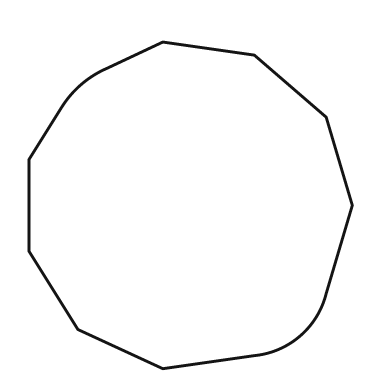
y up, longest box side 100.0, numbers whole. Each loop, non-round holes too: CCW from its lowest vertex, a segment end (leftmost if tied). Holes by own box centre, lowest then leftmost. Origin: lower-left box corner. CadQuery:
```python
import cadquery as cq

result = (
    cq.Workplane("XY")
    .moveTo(41.0, 0.0)
    .lineTo(69.0, 4.0)
    .threePointArc((83.0, 10.0), (91.0, 23.0))
    .lineTo(99.0, 50.0)
    .lineTo(91.0, 77.0)
    .lineTo(69.0, 96.0)
    .lineTo(41.0, 100.0)
    .lineTo(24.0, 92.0)
    .threePointArc((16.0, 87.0), (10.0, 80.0))
    .lineTo(0.0, 64.0)
    .lineTo(0.0, 36.0)
    .lineTo(15.0, 12.0)
    .close()
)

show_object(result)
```